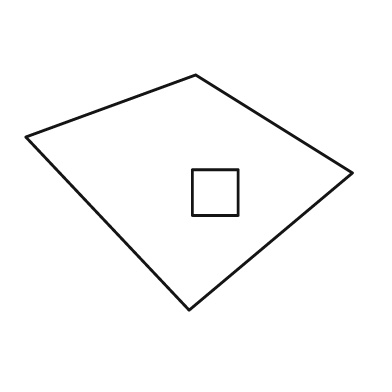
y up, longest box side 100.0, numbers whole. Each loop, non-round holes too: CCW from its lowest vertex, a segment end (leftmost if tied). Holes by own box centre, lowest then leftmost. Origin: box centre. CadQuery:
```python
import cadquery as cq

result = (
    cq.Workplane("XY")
    .moveTo(0.0, -36.0)
    .lineTo(50.0, 6.0)
    .lineTo(2.0, 36.0)
    .lineTo(-50.0, 17.0)
    .close()
    .moveTo(1.0, -7.0)
    .lineTo(15.0, -7.0)
    .lineTo(15.0, 7.0)
    .lineTo(1.0, 7.0)
    .close()
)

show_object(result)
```